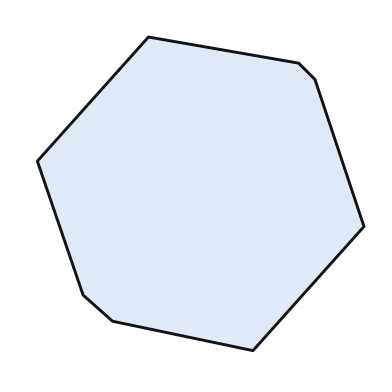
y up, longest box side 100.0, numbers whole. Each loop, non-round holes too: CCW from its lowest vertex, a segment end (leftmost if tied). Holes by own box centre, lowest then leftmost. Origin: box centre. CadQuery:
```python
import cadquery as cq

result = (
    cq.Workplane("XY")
    .moveTo(16.0, -48.0)
    .lineTo(50.0, -10.0)
    .lineTo(35.0, 35.0)
    .lineTo(30.0, 40.0)
    .lineTo(-16.0, 48.0)
    .lineTo(-50.0, 10.0)
    .lineTo(-36.0, -31.0)
    .lineTo(-27.0, -39.0)
    .close()
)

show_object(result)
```